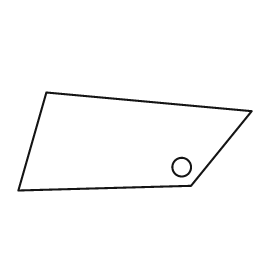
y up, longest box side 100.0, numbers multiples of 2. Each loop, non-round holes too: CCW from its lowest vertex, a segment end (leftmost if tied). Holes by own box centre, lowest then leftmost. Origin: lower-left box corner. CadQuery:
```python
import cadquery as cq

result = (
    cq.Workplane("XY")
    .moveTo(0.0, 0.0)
    .lineTo(74.0, 2.0)
    .lineTo(100.0, 34.0)
    .lineTo(12.0, 42.0)
    .close()
    .moveTo(70.0, 10.0)
    .circle(4.0)
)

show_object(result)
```